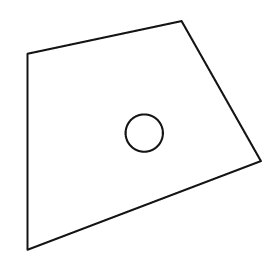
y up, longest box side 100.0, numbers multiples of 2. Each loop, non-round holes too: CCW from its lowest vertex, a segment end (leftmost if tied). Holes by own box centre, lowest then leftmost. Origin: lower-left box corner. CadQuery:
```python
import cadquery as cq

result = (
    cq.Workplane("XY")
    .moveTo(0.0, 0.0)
    .lineTo(100.0, 38.0)
    .lineTo(66.0, 98.0)
    .lineTo(0.0, 84.0)
    .close()
    .moveTo(50.0, 50.0)
    .circle(8.0)
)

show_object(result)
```